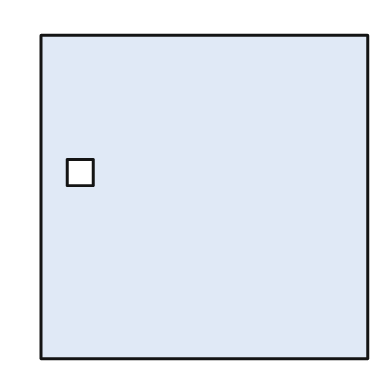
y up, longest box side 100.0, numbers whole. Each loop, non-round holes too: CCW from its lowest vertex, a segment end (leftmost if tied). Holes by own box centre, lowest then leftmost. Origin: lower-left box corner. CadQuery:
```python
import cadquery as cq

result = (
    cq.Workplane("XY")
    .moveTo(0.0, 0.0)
    .lineTo(100.0, 0.0)
    .lineTo(100.0, 99.0)
    .lineTo(0.0, 99.0)
    .close()
    .moveTo(8.0, 53.0)
    .lineTo(16.0, 53.0)
    .lineTo(16.0, 61.0)
    .lineTo(8.0, 61.0)
    .close()
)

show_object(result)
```